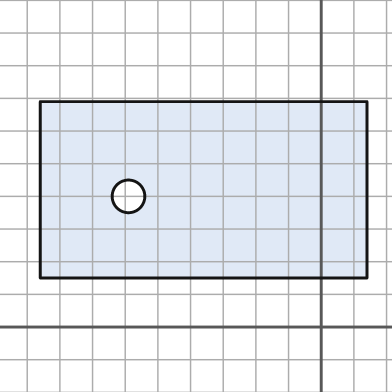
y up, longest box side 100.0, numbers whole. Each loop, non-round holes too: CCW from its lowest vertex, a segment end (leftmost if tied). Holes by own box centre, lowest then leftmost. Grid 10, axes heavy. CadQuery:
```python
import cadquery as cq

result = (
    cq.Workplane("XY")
    .moveTo(-86.0, 15.0)
    .lineTo(14.0, 15.0)
    .lineTo(14.0, 69.0)
    .lineTo(-86.0, 69.0)
    .close()
    .moveTo(-59.0, 40.0)
    .circle(5.0)
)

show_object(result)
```